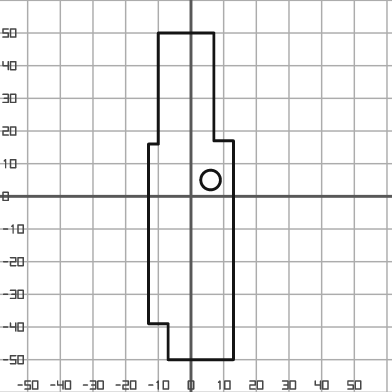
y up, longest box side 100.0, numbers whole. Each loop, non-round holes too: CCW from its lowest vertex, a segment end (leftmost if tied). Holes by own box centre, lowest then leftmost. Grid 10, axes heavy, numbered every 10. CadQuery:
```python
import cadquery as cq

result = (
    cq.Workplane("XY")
    .moveTo(-7.0, -50.0)
    .lineTo(13.0, -50.0)
    .lineTo(13.0, 17.0)
    .lineTo(7.0, 17.0)
    .lineTo(7.0, 50.0)
    .lineTo(-10.0, 50.0)
    .lineTo(-10.0, 16.0)
    .lineTo(-13.0, 16.0)
    .lineTo(-13.0, -39.0)
    .lineTo(-7.0, -39.0)
    .close()
    .moveTo(6.0, 5.0)
    .circle(3.0)
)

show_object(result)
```